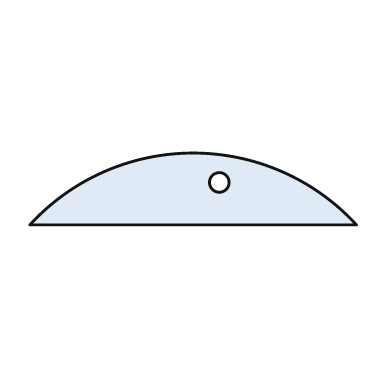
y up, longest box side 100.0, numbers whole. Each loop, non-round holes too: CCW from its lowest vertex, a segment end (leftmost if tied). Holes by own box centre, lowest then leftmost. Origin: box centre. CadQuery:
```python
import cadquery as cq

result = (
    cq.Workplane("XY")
    .moveTo(-50.0, -11.0)
    .lineTo(50.0, -11.0)
    .threePointArc((0.0, 11.0), (-50.0, -11.0))
    .close()
    .moveTo(8.0, 2.0)
    .circle(3.0)
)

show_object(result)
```